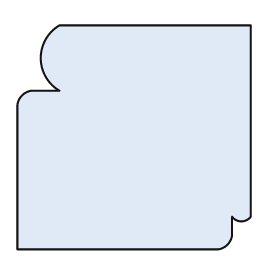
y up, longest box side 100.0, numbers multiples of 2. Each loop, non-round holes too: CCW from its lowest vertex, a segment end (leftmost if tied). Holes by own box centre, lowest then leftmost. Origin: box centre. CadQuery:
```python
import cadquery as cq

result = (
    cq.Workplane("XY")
    .moveTo(-50.0, -48.0)
    .lineTo(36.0, -48.0)
    .threePointArc((40.0, -46.0), (42.0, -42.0))
    .lineTo(42.0, -34.0)
    .threePointArc((46.0, -36.0), (50.0, -34.0))
    .lineTo(50.0, 48.0)
    .lineTo(-32.0, 48.0)
    .threePointArc((-40.0, 34.0), (-32.0, 20.0))
    .lineTo(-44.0, 20.0)
    .threePointArc((-48.0, 18.0), (-50.0, 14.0))
    .close()
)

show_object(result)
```